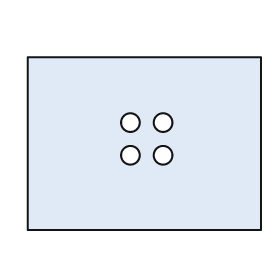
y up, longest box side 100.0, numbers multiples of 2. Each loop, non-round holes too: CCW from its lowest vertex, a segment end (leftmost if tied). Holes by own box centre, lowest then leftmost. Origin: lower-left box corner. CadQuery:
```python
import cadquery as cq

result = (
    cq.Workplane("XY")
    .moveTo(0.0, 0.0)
    .lineTo(100.0, 0.0)
    .lineTo(100.0, 74.0)
    .lineTo(0.0, 74.0)
    .close()
    .moveTo(44.0, 32.0)
    .circle(4.0)
    .moveTo(58.0, 32.0)
    .circle(4.0)
    .moveTo(44.0, 46.0)
    .circle(4.0)
    .moveTo(58.0, 46.0)
    .circle(4.0)
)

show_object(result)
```